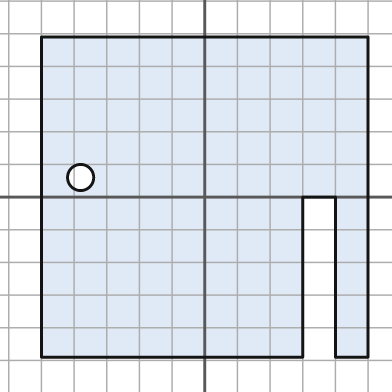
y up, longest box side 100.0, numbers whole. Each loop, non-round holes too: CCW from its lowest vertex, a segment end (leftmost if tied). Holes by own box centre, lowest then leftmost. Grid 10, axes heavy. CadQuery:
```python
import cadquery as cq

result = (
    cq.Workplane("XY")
    .moveTo(-50.0, -49.0)
    .lineTo(30.0, -49.0)
    .lineTo(30.0, 0.0)
    .lineTo(40.0, 0.0)
    .lineTo(40.0, -49.0)
    .lineTo(50.0, -49.0)
    .lineTo(50.0, 49.0)
    .lineTo(-50.0, 49.0)
    .close()
    .moveTo(-38.0, 6.0)
    .circle(4.0)
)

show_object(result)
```